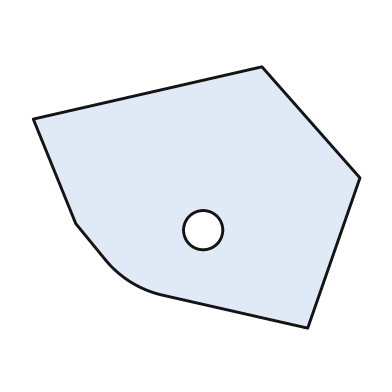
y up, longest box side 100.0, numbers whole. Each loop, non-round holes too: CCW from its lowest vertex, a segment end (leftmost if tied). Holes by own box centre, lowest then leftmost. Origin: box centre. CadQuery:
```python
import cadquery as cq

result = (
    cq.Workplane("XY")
    .moveTo(34.0, -40.0)
    .lineTo(50.0, 6.0)
    .lineTo(20.0, 40.0)
    .lineTo(-50.0, 24.0)
    .lineTo(-37.0, -8.0)
    .lineTo(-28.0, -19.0)
    .threePointArc((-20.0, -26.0), (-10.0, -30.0))
    .close()
    .moveTo(2.0, -10.0)
    .circle(6.0)
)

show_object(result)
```